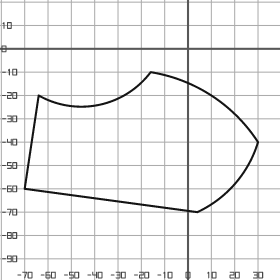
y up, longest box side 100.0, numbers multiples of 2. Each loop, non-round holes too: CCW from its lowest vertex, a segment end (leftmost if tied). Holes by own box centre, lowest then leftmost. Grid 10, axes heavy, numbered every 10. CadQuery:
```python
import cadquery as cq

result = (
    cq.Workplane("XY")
    .moveTo(4.0, -70.0)
    .threePointArc((20.0, -58.0), (30.0, -40.0))
    .threePointArc((10.0, -20.0), (-16.0, -10.0))
    .threePointArc((-38.0, -24.0), (-64.0, -20.0))
    .lineTo(-70.0, -60.0)
    .close()
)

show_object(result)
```